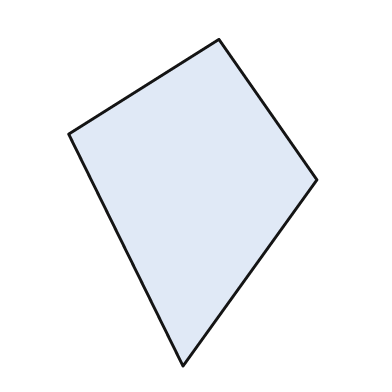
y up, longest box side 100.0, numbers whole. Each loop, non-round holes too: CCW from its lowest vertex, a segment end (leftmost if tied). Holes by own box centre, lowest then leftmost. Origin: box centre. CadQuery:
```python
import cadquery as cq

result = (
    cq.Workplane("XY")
    .moveTo(-3.0, -50.0)
    .lineTo(38.0, 7.0)
    .lineTo(8.0, 50.0)
    .lineTo(-38.0, 21.0)
    .close()
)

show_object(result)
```